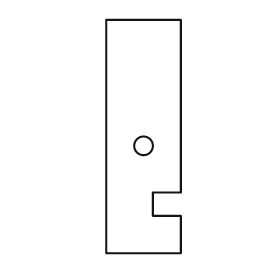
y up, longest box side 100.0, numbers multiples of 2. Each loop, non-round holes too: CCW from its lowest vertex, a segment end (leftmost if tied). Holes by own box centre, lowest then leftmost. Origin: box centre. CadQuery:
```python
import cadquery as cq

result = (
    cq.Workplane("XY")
    .moveTo(-16.0, -50.0)
    .lineTo(16.0, -50.0)
    .lineTo(16.0, -34.0)
    .lineTo(4.0, -34.0)
    .lineTo(4.0, -24.0)
    .lineTo(16.0, -24.0)
    .lineTo(16.0, 50.0)
    .lineTo(-16.0, 50.0)
    .close()
    .moveTo(0.0, -4.0)
    .circle(4.0)
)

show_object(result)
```